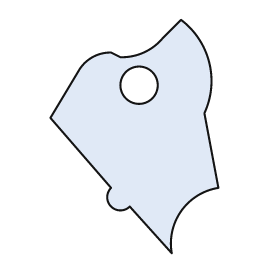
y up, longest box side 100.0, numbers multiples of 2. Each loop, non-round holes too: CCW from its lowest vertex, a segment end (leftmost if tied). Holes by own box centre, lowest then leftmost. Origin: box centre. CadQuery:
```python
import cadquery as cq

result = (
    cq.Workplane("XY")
    .moveTo(16.0, -50.0)
    .threePointArc((20.0, -32.0), (36.0, -22.0))
    .lineTo(30.0, 10.0)
    .threePointArc((32.0, 32.0), (20.0, 50.0))
    .lineTo(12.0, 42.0)
    .threePointArc((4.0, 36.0), (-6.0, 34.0))
    .lineTo(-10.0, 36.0)
    .threePointArc((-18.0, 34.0), (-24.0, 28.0))
    .lineTo(-36.0, 8.0)
    .lineTo(-10.0, -22.0)
    .threePointArc((-10.0, -30.0), (-2.0, -30.0))
    .close()
    .moveTo(2.0, 22.0)
    .circle(8.0)
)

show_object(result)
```